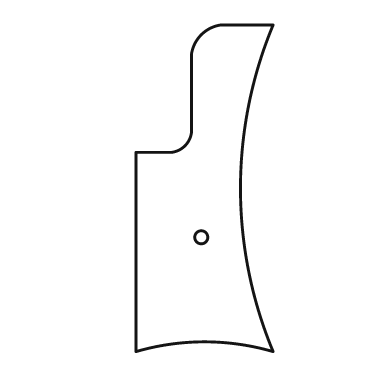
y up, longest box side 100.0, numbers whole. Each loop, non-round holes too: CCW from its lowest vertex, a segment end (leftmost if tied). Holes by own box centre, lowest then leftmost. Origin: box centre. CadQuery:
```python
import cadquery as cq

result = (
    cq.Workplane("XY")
    .moveTo(-21.0, -50.0)
    .threePointArc((0.0, -47.0), (21.0, -50.0))
    .threePointArc((11.0, 0.0), (21.0, 50.0))
    .lineTo(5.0, 50.0)
    .threePointArc((-1.0, 47.0), (-4.0, 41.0))
    .lineTo(-4.0, 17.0)
    .threePointArc((-6.0, 13.0), (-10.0, 11.0))
    .lineTo(-21.0, 11.0)
    .close()
    .moveTo(-1.0, -15.0)
    .circle(2.0)
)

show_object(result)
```